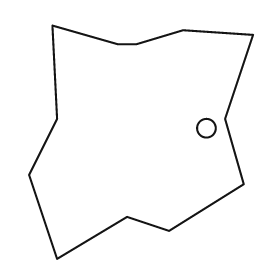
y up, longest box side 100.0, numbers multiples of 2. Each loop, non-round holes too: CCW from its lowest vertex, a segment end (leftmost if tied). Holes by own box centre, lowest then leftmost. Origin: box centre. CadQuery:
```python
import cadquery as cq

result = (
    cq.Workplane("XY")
    .moveTo(-36.0, -50.0)
    .lineTo(-6.0, -32.0)
    .lineTo(12.0, -38.0)
    .lineTo(44.0, -18.0)
    .lineTo(36.0, 10.0)
    .lineTo(48.0, 46.0)
    .lineTo(18.0, 48.0)
    .lineTo(-2.0, 42.0)
    .lineTo(-10.0, 42.0)
    .lineTo(-38.0, 50.0)
    .lineTo(-36.0, 10.0)
    .lineTo(-48.0, -14.0)
    .close()
    .moveTo(28.0, 6.0)
    .circle(4.0)
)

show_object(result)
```